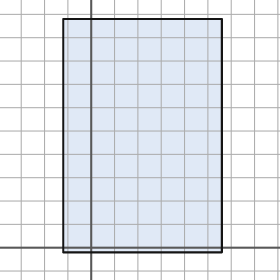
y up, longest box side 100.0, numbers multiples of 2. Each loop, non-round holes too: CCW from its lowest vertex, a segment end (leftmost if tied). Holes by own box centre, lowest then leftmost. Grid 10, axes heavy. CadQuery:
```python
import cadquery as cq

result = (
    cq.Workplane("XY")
    .moveTo(-12.0, -2.0)
    .lineTo(56.0, -2.0)
    .lineTo(56.0, 98.0)
    .lineTo(-12.0, 98.0)
    .close()
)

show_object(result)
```